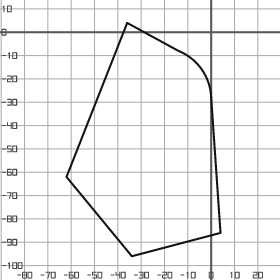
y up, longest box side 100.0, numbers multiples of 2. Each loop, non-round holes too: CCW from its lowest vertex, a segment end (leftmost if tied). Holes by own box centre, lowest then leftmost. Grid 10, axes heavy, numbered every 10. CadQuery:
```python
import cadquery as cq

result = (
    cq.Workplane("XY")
    .moveTo(-34.0, -96.0)
    .lineTo(4.0, -86.0)
    .lineTo(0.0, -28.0)
    .threePointArc((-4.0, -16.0), (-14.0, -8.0))
    .lineTo(-36.0, 4.0)
    .lineTo(-62.0, -62.0)
    .close()
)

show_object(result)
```